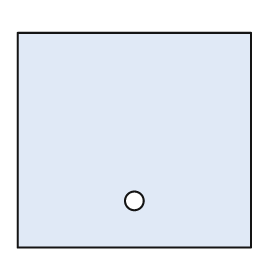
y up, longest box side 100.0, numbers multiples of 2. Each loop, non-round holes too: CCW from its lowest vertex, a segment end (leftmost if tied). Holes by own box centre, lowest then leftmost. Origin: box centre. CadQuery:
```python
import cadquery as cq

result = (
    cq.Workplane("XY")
    .moveTo(-50.0, -46.0)
    .lineTo(50.0, -46.0)
    .lineTo(50.0, 46.0)
    .lineTo(-50.0, 46.0)
    .close()
    .moveTo(0.0, -26.0)
    .circle(4.0)
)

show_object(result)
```